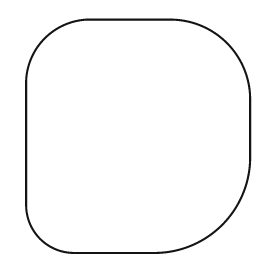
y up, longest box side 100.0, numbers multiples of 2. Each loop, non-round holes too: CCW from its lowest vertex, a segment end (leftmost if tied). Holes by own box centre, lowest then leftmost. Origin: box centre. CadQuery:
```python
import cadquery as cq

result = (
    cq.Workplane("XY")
    .moveTo(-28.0, -50.0)
    .lineTo(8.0, -50.0)
    .threePointArc((36.0, -38.0), (48.0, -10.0))
    .lineTo(48.0, 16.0)
    .threePointArc((38.0, 40.0), (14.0, 50.0))
    .lineTo(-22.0, 50.0)
    .threePointArc((-40.0, 42.0), (-48.0, 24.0))
    .lineTo(-48.0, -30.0)
    .threePointArc((-42.0, -44.0), (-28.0, -50.0))
    .close()
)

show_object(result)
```